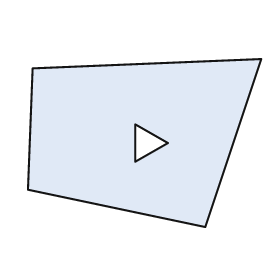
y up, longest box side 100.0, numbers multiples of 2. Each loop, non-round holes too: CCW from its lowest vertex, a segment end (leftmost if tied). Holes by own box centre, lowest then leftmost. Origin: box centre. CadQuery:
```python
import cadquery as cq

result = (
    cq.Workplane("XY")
    .moveTo(26.0, -36.0)
    .lineTo(50.0, 36.0)
    .lineTo(-48.0, 32.0)
    .lineTo(-50.0, -20.0)
    .close()
    .moveTo(-4.0, -8.0)
    .lineTo(10.0, 0.0)
    .lineTo(-4.0, 8.0)
    .close()
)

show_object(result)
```